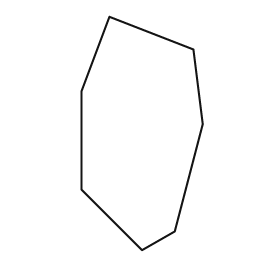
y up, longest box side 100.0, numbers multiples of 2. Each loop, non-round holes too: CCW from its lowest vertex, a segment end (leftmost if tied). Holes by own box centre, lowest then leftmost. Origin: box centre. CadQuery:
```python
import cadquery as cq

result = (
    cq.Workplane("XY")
    .moveTo(0.0, -50.0)
    .lineTo(14.0, -42.0)
    .lineTo(26.0, 4.0)
    .lineTo(22.0, 36.0)
    .lineTo(-14.0, 50.0)
    .lineTo(-26.0, 18.0)
    .lineTo(-26.0, -24.0)
    .close()
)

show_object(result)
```